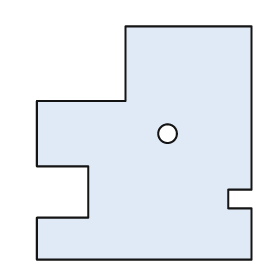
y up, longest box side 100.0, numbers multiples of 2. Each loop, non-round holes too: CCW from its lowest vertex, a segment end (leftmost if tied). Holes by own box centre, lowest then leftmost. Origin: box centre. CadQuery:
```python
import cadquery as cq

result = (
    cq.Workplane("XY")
    .moveTo(-46.0, -50.0)
    .lineTo(46.0, -50.0)
    .lineTo(46.0, -28.0)
    .lineTo(36.0, -28.0)
    .lineTo(36.0, -20.0)
    .lineTo(46.0, -20.0)
    .lineTo(46.0, 50.0)
    .lineTo(-8.0, 50.0)
    .lineTo(-8.0, 18.0)
    .lineTo(-46.0, 18.0)
    .lineTo(-46.0, -10.0)
    .lineTo(-24.0, -10.0)
    .lineTo(-24.0, -32.0)
    .lineTo(-46.0, -32.0)
    .close()
    .moveTo(10.0, 4.0)
    .circle(4.0)
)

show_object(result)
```